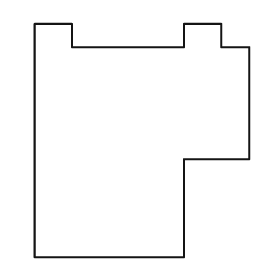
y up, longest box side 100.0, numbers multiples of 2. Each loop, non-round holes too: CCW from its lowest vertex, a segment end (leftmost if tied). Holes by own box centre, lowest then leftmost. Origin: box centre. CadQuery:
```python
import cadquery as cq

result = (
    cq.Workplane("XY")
    .moveTo(-46.0, -50.0)
    .lineTo(18.0, -50.0)
    .lineTo(18.0, -8.0)
    .lineTo(46.0, -8.0)
    .lineTo(46.0, 40.0)
    .lineTo(34.0, 40.0)
    .lineTo(34.0, 50.0)
    .lineTo(18.0, 50.0)
    .lineTo(18.0, 40.0)
    .lineTo(-30.0, 40.0)
    .lineTo(-30.0, 50.0)
    .lineTo(-46.0, 50.0)
    .close()
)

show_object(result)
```